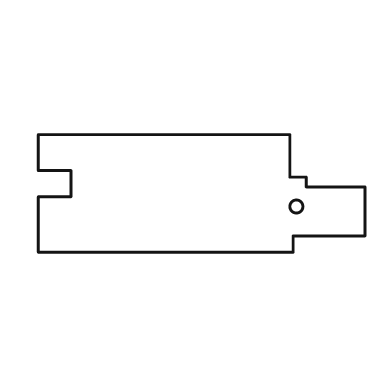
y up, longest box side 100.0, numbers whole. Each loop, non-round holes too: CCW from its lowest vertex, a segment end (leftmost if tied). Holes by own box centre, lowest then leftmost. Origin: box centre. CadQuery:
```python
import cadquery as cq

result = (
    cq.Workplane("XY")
    .moveTo(-50.0, -18.0)
    .lineTo(28.0, -18.0)
    .lineTo(28.0, -13.0)
    .lineTo(50.0, -13.0)
    .lineTo(50.0, 2.0)
    .lineTo(32.0, 2.0)
    .lineTo(32.0, 5.0)
    .lineTo(27.0, 5.0)
    .lineTo(27.0, 18.0)
    .lineTo(-50.0, 18.0)
    .lineTo(-50.0, 7.0)
    .lineTo(-40.0, 7.0)
    .lineTo(-40.0, -1.0)
    .lineTo(-50.0, -1.0)
    .close()
    .moveTo(29.0, -4.0)
    .circle(2.0)
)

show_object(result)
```